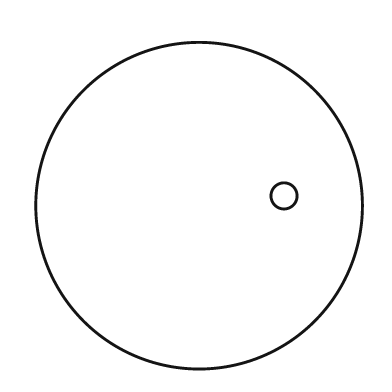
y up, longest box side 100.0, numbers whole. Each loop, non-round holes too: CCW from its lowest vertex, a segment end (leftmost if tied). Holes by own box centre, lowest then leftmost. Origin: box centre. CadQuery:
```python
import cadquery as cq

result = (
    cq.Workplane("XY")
    .moveTo(0.0, 0.0)
    .circle(50.0)
    .moveTo(26.0, 3.0)
    .circle(4.0)
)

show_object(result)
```